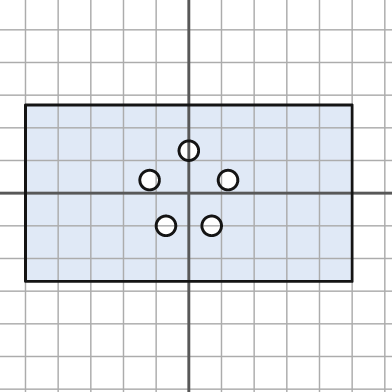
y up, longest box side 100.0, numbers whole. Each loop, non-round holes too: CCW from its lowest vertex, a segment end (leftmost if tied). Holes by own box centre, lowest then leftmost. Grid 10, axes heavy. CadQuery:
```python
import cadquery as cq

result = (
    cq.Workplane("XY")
    .moveTo(-50.0, -27.0)
    .lineTo(50.0, -27.0)
    .lineTo(50.0, 27.0)
    .lineTo(-50.0, 27.0)
    .close()
    .moveTo(-7.0, -10.0)
    .circle(3.0)
    .moveTo(7.0, -10.0)
    .circle(3.0)
    .moveTo(-12.0, 4.0)
    .circle(3.0)
    .moveTo(12.0, 4.0)
    .circle(3.0)
    .moveTo(0.0, 13.0)
    .circle(3.0)
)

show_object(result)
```